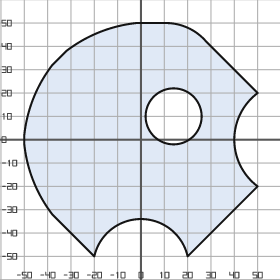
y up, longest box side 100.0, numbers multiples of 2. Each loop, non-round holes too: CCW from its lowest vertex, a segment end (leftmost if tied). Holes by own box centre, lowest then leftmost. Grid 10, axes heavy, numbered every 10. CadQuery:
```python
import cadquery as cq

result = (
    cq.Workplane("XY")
    .moveTo(-20.0, -50.0)
    .threePointArc((0.0, -34.0), (20.0, -50.0))
    .lineTo(50.0, -20.0)
    .threePointArc((40.0, 0.0), (50.0, 20.0))
    .lineTo(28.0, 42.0)
    .threePointArc((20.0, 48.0), (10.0, 50.0))
    .lineTo(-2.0, 50.0)
    .threePointArc((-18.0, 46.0), (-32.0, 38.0))
    .lineTo(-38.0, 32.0)
    .threePointArc((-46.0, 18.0), (-50.0, 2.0))
    .lineTo(-50.0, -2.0)
    .threePointArc((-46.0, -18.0), (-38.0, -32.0))
    .close()
    .moveTo(14.0, 10.0)
    .circle(12.0)
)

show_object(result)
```